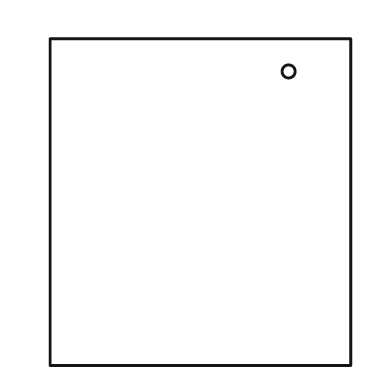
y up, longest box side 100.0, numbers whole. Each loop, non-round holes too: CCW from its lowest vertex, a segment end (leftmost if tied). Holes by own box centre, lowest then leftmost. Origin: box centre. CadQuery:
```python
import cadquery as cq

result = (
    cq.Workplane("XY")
    .moveTo(-46.0, -50.0)
    .lineTo(46.0, -50.0)
    .lineTo(46.0, 50.0)
    .lineTo(-46.0, 50.0)
    .close()
    .moveTo(27.0, 40.0)
    .circle(2.0)
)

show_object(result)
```